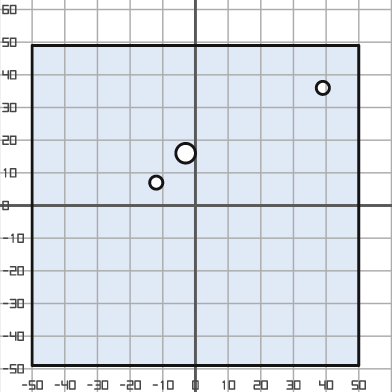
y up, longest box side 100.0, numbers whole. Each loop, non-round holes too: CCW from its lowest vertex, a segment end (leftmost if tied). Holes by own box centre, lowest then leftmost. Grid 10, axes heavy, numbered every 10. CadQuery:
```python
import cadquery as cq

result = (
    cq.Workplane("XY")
    .moveTo(-50.0, -49.0)
    .lineTo(50.0, -49.0)
    .lineTo(50.0, 49.0)
    .lineTo(-50.0, 49.0)
    .close()
    .moveTo(-12.0, 7.0)
    .circle(2.0)
    .moveTo(-3.0, 16.0)
    .circle(3.0)
    .moveTo(39.0, 36.0)
    .circle(2.0)
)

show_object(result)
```